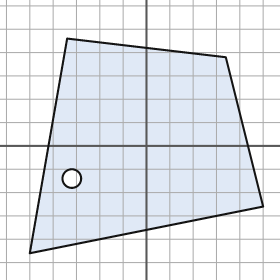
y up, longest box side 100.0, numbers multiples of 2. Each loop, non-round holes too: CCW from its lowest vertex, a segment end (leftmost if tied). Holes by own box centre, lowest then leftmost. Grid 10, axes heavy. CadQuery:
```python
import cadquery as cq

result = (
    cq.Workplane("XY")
    .moveTo(-50.0, -46.0)
    .lineTo(50.0, -26.0)
    .lineTo(34.0, 38.0)
    .lineTo(-34.0, 46.0)
    .close()
    .moveTo(-32.0, -14.0)
    .circle(4.0)
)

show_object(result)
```